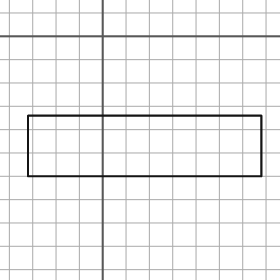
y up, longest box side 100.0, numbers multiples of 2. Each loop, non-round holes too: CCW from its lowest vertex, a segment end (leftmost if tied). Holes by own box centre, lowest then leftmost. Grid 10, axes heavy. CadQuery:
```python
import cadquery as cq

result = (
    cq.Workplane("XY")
    .moveTo(-32.0, -60.0)
    .lineTo(68.0, -60.0)
    .lineTo(68.0, -34.0)
    .lineTo(-32.0, -34.0)
    .close()
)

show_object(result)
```